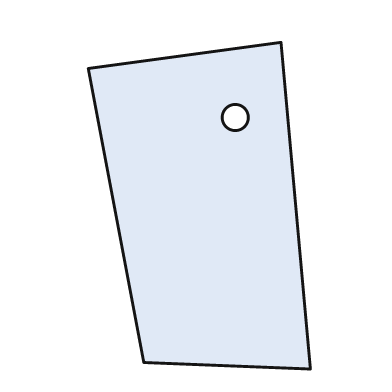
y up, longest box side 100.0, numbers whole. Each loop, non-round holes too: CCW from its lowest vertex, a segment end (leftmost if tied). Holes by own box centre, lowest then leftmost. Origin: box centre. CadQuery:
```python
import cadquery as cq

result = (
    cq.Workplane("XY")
    .moveTo(34.0, -50.0)
    .lineTo(25.0, 50.0)
    .lineTo(-34.0, 42.0)
    .lineTo(-17.0, -48.0)
    .close()
    .moveTo(11.0, 27.0)
    .circle(4.0)
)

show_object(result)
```